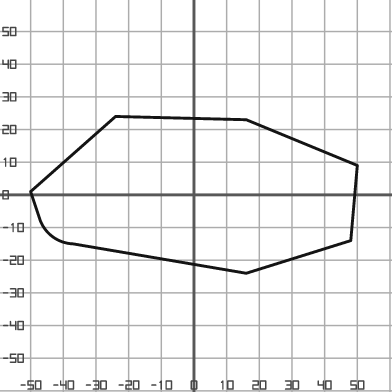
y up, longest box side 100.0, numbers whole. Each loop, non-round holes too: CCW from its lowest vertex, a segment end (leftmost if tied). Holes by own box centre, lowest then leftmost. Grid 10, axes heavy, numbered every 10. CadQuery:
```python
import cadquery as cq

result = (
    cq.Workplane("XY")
    .moveTo(16.0, -24.0)
    .lineTo(48.0, -14.0)
    .lineTo(50.0, 9.0)
    .lineTo(16.0, 23.0)
    .lineTo(-24.0, 24.0)
    .lineTo(-50.0, 1.0)
    .lineTo(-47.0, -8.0)
    .threePointArc((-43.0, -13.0), (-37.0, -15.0))
    .close()
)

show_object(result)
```